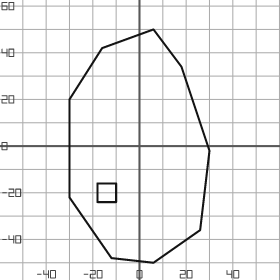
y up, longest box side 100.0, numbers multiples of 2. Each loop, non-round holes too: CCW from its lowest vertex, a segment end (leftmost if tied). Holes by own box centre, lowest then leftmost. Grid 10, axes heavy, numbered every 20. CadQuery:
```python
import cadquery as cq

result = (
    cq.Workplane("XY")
    .moveTo(6.0, -50.0)
    .lineTo(26.0, -36.0)
    .lineTo(30.0, -2.0)
    .lineTo(18.0, 34.0)
    .lineTo(6.0, 50.0)
    .lineTo(-16.0, 42.0)
    .lineTo(-30.0, 20.0)
    .lineTo(-30.0, -22.0)
    .lineTo(-12.0, -48.0)
    .close()
    .moveTo(-18.0, -24.0)
    .lineTo(-10.0, -24.0)
    .lineTo(-10.0, -16.0)
    .lineTo(-18.0, -16.0)
    .close()
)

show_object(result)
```